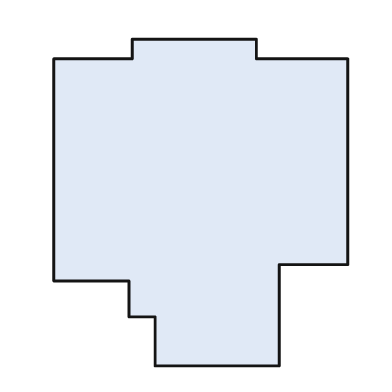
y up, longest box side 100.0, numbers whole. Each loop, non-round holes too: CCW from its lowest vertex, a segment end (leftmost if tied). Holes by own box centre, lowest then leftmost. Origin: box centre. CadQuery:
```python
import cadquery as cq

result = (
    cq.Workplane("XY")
    .moveTo(-14.0, -50.0)
    .lineTo(24.0, -50.0)
    .lineTo(24.0, -19.0)
    .lineTo(45.0, -19.0)
    .lineTo(45.0, 44.0)
    .lineTo(17.0, 44.0)
    .lineTo(17.0, 50.0)
    .lineTo(-21.0, 50.0)
    .lineTo(-21.0, 44.0)
    .lineTo(-45.0, 44.0)
    .lineTo(-45.0, -24.0)
    .lineTo(-22.0, -24.0)
    .lineTo(-22.0, -35.0)
    .lineTo(-14.0, -35.0)
    .close()
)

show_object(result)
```